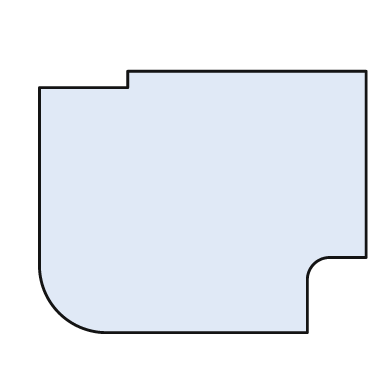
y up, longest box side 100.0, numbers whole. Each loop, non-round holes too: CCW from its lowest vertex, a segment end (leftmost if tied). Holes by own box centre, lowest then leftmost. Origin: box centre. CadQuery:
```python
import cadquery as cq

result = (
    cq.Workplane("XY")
    .moveTo(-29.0, -40.0)
    .lineTo(32.0, -40.0)
    .lineTo(32.0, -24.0)
    .threePointArc((34.0, -19.0), (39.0, -17.0))
    .lineTo(50.0, -17.0)
    .lineTo(50.0, 40.0)
    .lineTo(-23.0, 40.0)
    .lineTo(-23.0, 35.0)
    .lineTo(-50.0, 35.0)
    .lineTo(-50.0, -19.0)
    .threePointArc((-44.0, -34.0), (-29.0, -40.0))
    .close()
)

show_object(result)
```